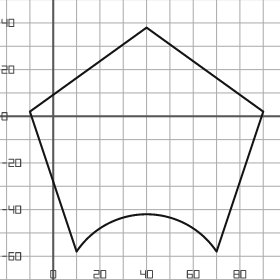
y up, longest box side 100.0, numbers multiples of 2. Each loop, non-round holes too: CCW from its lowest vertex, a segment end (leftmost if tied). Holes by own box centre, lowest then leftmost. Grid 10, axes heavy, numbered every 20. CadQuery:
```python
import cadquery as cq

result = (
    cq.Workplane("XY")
    .moveTo(10.0, -58.0)
    .threePointArc((40.0, -42.0), (70.0, -58.0))
    .lineTo(90.0, 2.0)
    .lineTo(40.0, 38.0)
    .lineTo(-10.0, 2.0)
    .close()
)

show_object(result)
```